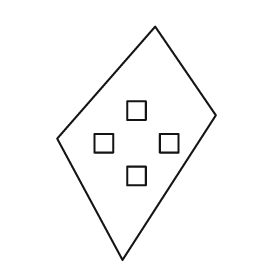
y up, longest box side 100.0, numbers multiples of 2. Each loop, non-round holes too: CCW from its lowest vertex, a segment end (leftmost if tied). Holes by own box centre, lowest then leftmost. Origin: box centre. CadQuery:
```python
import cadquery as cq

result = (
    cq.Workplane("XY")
    .moveTo(-6.0, -50.0)
    .lineTo(34.0, 12.0)
    .lineTo(8.0, 50.0)
    .lineTo(-34.0, 2.0)
    .close()
    .moveTo(-4.0, -18.0)
    .lineTo(4.0, -18.0)
    .lineTo(4.0, -10.0)
    .lineTo(-4.0, -10.0)
    .close()
    .moveTo(-18.0, -4.0)
    .lineTo(-10.0, -4.0)
    .lineTo(-10.0, 4.0)
    .lineTo(-18.0, 4.0)
    .close()
    .moveTo(10.0, -4.0)
    .lineTo(18.0, -4.0)
    .lineTo(18.0, 4.0)
    .lineTo(10.0, 4.0)
    .close()
    .moveTo(-4.0, 10.0)
    .lineTo(4.0, 10.0)
    .lineTo(4.0, 18.0)
    .lineTo(-4.0, 18.0)
    .close()
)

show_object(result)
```